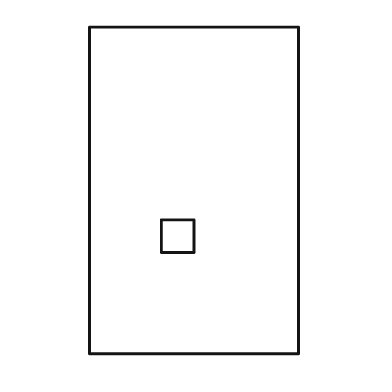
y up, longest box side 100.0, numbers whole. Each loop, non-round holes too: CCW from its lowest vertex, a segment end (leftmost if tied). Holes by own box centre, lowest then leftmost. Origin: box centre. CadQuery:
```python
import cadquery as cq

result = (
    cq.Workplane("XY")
    .moveTo(-32.0, -50.0)
    .lineTo(32.0, -50.0)
    .lineTo(32.0, 50.0)
    .lineTo(-32.0, 50.0)
    .close()
    .moveTo(-10.0, -19.0)
    .lineTo(0.0, -19.0)
    .lineTo(0.0, -9.0)
    .lineTo(-10.0, -9.0)
    .close()
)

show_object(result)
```